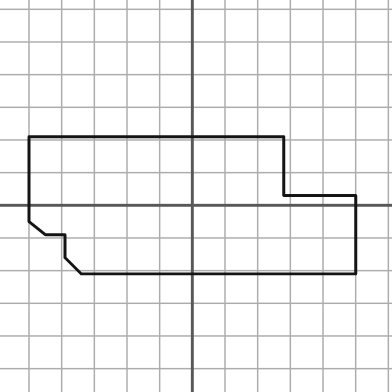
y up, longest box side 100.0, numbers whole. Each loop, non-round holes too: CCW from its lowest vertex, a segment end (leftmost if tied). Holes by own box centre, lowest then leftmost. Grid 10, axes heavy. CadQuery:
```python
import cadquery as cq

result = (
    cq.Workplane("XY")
    .moveTo(-34.0, -21.0)
    .lineTo(50.0, -21.0)
    .lineTo(50.0, 3.0)
    .lineTo(28.0, 3.0)
    .lineTo(28.0, 21.0)
    .lineTo(-50.0, 21.0)
    .lineTo(-50.0, -5.0)
    .lineTo(-45.0, -9.0)
    .lineTo(-39.0, -9.0)
    .lineTo(-39.0, -16.0)
    .close()
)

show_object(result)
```